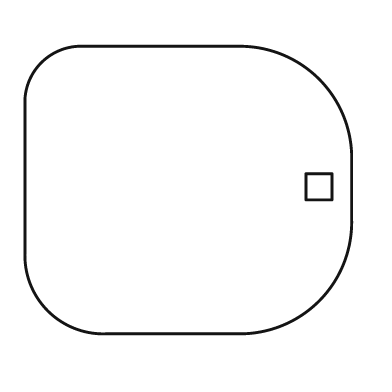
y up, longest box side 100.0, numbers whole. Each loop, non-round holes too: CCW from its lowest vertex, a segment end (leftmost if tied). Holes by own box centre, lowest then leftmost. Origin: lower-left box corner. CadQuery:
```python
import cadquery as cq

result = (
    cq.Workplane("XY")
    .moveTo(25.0, 0.0)
    .lineTo(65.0, 0.0)
    .threePointArc((90.0, 10.0), (100.0, 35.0))
    .lineTo(100.0, 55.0)
    .threePointArc((90.0, 78.0), (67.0, 88.0))
    .lineTo(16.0, 88.0)
    .threePointArc((5.0, 83.0), (0.0, 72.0))
    .lineTo(0.0, 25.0)
    .threePointArc((7.0, 7.0), (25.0, 0.0))
    .close()
    .moveTo(86.0, 41.0)
    .lineTo(94.0, 41.0)
    .lineTo(94.0, 49.0)
    .lineTo(86.0, 49.0)
    .close()
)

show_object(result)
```